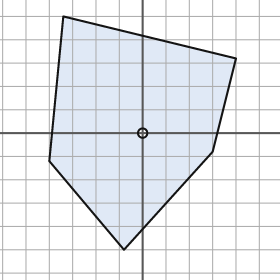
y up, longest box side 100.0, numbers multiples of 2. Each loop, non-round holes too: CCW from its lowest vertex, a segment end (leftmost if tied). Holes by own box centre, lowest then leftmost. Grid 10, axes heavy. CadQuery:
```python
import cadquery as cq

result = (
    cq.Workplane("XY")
    .moveTo(-8.0, -50.0)
    .lineTo(30.0, -8.0)
    .lineTo(40.0, 32.0)
    .lineTo(-34.0, 50.0)
    .lineTo(-40.0, -12.0)
    .close()
    .moveTo(0.0, 0.0)
    .circle(2.0)
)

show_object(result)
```